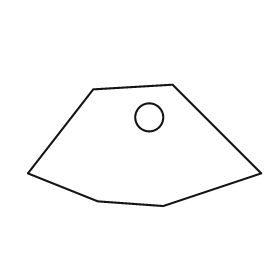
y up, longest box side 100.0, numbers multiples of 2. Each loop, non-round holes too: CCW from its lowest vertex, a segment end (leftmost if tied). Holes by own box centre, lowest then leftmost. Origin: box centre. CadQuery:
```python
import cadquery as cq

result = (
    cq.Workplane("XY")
    .moveTo(8.0, -26.0)
    .lineTo(50.0, -12.0)
    .lineTo(12.0, 26.0)
    .lineTo(-22.0, 24.0)
    .lineTo(-50.0, -12.0)
    .lineTo(-20.0, -24.0)
    .close()
    .moveTo(2.0, 12.0)
    .circle(6.0)
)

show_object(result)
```